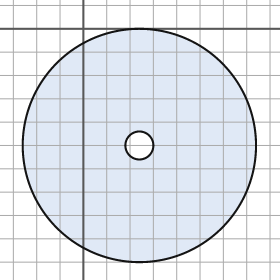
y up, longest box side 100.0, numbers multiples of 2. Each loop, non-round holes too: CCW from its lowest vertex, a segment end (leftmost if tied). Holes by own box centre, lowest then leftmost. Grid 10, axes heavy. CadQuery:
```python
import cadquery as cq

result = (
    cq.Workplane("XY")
    .moveTo(24.0, -50.0)
    .circle(50.0)
    .moveTo(24.0, -50.0)
    .circle(6.0)
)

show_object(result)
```